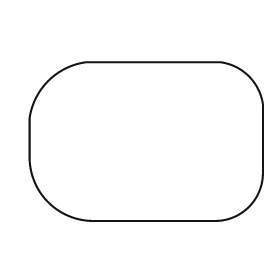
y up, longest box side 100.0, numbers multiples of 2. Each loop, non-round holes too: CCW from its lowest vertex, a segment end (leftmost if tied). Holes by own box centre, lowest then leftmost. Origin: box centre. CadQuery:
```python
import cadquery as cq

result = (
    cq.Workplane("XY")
    .moveTo(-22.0, -34.0)
    .lineTo(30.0, -34.0)
    .threePointArc((44.0, -28.0), (50.0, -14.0))
    .lineTo(50.0, 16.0)
    .threePointArc((44.0, 28.0), (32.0, 34.0))
    .lineTo(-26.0, 34.0)
    .threePointArc((-42.0, 26.0), (-50.0, 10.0))
    .lineTo(-50.0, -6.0)
    .threePointArc((-42.0, -26.0), (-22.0, -34.0))
    .close()
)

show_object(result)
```